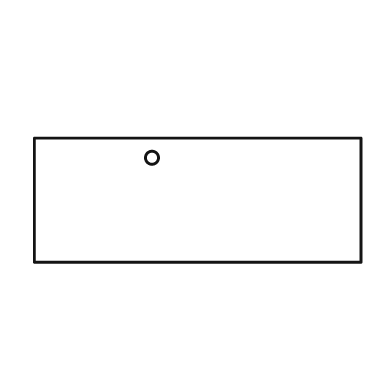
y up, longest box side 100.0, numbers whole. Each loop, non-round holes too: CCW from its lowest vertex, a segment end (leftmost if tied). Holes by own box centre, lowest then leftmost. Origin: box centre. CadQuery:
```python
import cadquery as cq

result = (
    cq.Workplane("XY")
    .moveTo(-50.0, -19.0)
    .lineTo(50.0, -19.0)
    .lineTo(50.0, 19.0)
    .lineTo(-50.0, 19.0)
    .close()
    .moveTo(-14.0, 13.0)
    .circle(2.0)
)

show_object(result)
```